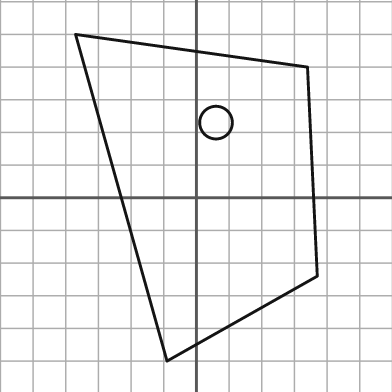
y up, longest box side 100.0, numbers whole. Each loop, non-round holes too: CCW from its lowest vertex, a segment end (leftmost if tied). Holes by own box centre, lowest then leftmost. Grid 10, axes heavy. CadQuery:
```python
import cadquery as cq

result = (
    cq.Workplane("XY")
    .moveTo(-9.0, -50.0)
    .lineTo(37.0, -24.0)
    .lineTo(34.0, 40.0)
    .lineTo(-37.0, 50.0)
    .close()
    .moveTo(6.0, 23.0)
    .circle(5.0)
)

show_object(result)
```